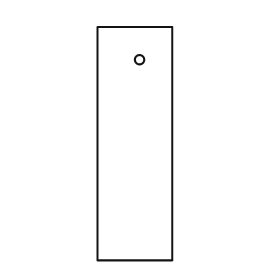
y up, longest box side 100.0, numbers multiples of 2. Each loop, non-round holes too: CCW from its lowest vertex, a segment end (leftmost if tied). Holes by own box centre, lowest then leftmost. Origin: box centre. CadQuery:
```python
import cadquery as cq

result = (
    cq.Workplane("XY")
    .moveTo(-16.0, -50.0)
    .lineTo(16.0, -50.0)
    .lineTo(16.0, 50.0)
    .lineTo(-16.0, 50.0)
    .close()
    .moveTo(2.0, 36.0)
    .circle(2.0)
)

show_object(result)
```